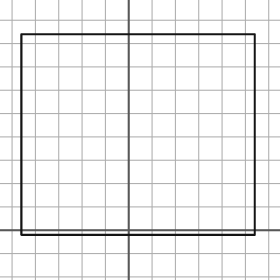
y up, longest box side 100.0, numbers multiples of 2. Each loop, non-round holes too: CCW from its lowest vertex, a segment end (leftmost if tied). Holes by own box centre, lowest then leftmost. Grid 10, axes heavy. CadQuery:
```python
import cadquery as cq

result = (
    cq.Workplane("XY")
    .moveTo(-46.0, -2.0)
    .lineTo(54.0, -2.0)
    .lineTo(54.0, 84.0)
    .lineTo(-46.0, 84.0)
    .close()
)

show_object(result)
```